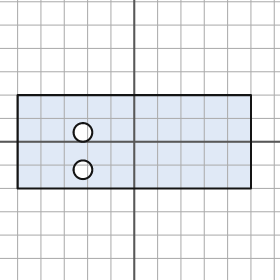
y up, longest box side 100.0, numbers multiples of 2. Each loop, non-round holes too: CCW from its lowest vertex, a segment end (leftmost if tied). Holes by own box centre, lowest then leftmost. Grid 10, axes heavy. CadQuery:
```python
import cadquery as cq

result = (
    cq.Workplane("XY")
    .moveTo(-50.0, -20.0)
    .lineTo(50.0, -20.0)
    .lineTo(50.0, 20.0)
    .lineTo(-50.0, 20.0)
    .close()
    .moveTo(-22.0, -12.0)
    .circle(4.0)
    .moveTo(-22.0, 4.0)
    .circle(4.0)
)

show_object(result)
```